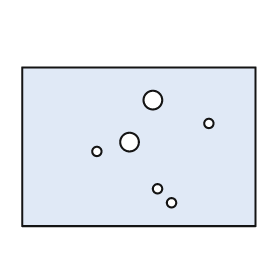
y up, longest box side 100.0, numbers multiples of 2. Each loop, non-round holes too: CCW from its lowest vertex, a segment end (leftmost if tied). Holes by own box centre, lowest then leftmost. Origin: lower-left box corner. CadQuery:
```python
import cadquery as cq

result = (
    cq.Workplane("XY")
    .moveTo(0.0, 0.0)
    .lineTo(100.0, 0.0)
    .lineTo(100.0, 68.0)
    .lineTo(0.0, 68.0)
    .close()
    .moveTo(64.0, 10.0)
    .circle(2.0)
    .moveTo(58.0, 16.0)
    .circle(2.0)
    .moveTo(32.0, 32.0)
    .circle(2.0)
    .moveTo(46.0, 36.0)
    .circle(4.0)
    .moveTo(80.0, 44.0)
    .circle(2.0)
    .moveTo(56.0, 54.0)
    .circle(4.0)
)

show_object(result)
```